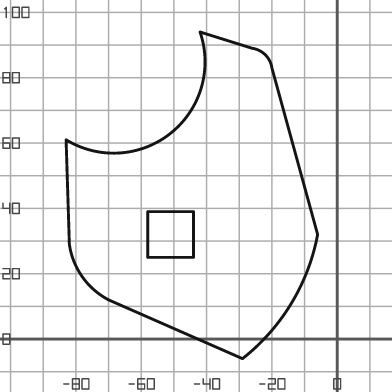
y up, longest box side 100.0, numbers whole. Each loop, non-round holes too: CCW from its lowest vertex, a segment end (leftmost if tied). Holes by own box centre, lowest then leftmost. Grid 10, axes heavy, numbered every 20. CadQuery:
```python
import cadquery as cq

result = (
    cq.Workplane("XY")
    .moveTo(-29.0, -6.0)
    .threePointArc((-14.0, 11.0), (-6.0, 32.0))
    .lineTo(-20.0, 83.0)
    .threePointArc((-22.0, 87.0), (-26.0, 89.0))
    .lineTo(-42.0, 94.0)
    .threePointArc((-51.0, 63.0), (-83.0, 61.0))
    .lineTo(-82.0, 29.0)
    .threePointArc((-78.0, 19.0), (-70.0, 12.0))
    .close()
    .moveTo(-58.0, 25.0)
    .lineTo(-44.0, 25.0)
    .lineTo(-44.0, 39.0)
    .lineTo(-58.0, 39.0)
    .close()
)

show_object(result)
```